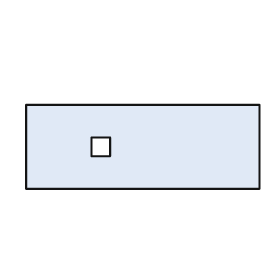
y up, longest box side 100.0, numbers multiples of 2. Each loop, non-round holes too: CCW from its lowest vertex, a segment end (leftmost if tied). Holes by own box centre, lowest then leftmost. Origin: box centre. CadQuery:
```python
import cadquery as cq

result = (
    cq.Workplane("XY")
    .moveTo(-50.0, -18.0)
    .lineTo(50.0, -18.0)
    .lineTo(50.0, 18.0)
    .lineTo(-50.0, 18.0)
    .close()
    .moveTo(-22.0, -4.0)
    .lineTo(-14.0, -4.0)
    .lineTo(-14.0, 4.0)
    .lineTo(-22.0, 4.0)
    .close()
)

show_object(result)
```